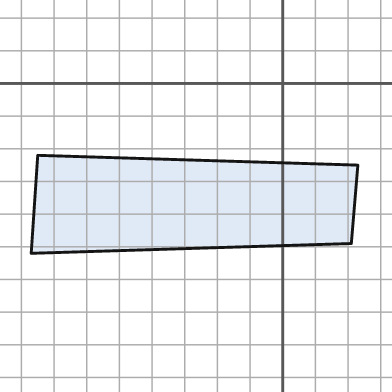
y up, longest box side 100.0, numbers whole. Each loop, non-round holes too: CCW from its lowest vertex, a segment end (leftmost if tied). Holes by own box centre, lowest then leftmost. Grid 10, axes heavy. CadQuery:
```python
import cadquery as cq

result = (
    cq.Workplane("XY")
    .moveTo(-77.0, -52.0)
    .lineTo(21.0, -49.0)
    .lineTo(23.0, -25.0)
    .lineTo(-75.0, -22.0)
    .close()
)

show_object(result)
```